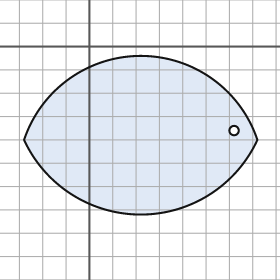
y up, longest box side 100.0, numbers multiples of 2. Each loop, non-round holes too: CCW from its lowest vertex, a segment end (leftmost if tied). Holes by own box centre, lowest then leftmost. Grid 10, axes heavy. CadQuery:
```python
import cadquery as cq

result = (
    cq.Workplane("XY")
    .moveTo(-28.0, -40.0)
    .threePointArc((22.0, -72.0), (72.0, -40.0))
    .threePointArc((22.0, -4.0), (-28.0, -40.0))
    .close()
    .moveTo(62.0, -36.0)
    .circle(2.0)
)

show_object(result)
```